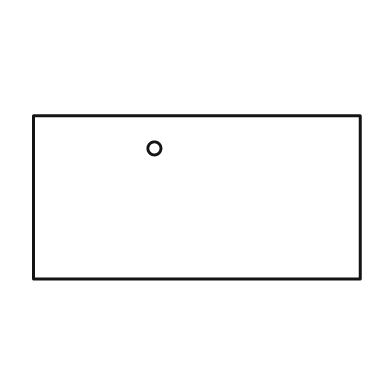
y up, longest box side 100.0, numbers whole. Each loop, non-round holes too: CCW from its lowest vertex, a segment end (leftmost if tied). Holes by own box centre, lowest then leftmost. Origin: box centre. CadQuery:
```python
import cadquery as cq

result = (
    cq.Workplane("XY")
    .moveTo(-50.0, -25.0)
    .lineTo(50.0, -25.0)
    .lineTo(50.0, 25.0)
    .lineTo(-50.0, 25.0)
    .close()
    .moveTo(-13.0, 15.0)
    .circle(2.0)
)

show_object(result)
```